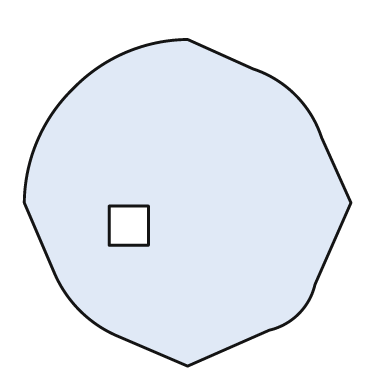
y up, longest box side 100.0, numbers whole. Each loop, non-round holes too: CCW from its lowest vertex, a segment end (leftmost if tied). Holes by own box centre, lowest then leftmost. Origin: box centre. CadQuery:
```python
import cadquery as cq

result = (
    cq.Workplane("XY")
    .moveTo(0.0, -50.0)
    .lineTo(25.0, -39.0)
    .threePointArc((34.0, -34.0), (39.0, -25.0))
    .lineTo(50.0, 0.0)
    .lineTo(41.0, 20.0)
    .threePointArc((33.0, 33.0), (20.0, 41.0))
    .lineTo(0.0, 50.0)
    .threePointArc((-19.0, 46.0), (-35.0, 35.0))
    .threePointArc((-46.0, 19.0), (-50.0, 0.0))
    .lineTo(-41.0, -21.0)
    .threePointArc((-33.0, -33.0), (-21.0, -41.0))
    .close()
    .moveTo(-24.0, -13.0)
    .lineTo(-12.0, -13.0)
    .lineTo(-12.0, -1.0)
    .lineTo(-24.0, -1.0)
    .close()
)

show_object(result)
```